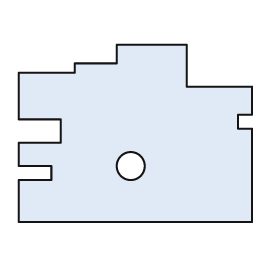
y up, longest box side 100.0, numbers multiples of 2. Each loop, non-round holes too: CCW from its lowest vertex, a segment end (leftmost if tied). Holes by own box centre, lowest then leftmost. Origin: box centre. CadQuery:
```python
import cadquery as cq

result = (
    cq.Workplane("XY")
    .moveTo(-50.0, -38.0)
    .lineTo(50.0, -38.0)
    .lineTo(50.0, 2.0)
    .lineTo(44.0, 2.0)
    .lineTo(44.0, 8.0)
    .lineTo(50.0, 8.0)
    .lineTo(50.0, 20.0)
    .lineTo(22.0, 20.0)
    .lineTo(22.0, 38.0)
    .lineTo(-8.0, 38.0)
    .lineTo(-8.0, 30.0)
    .lineTo(-26.0, 30.0)
    .lineTo(-26.0, 26.0)
    .lineTo(-50.0, 26.0)
    .lineTo(-50.0, 6.0)
    .lineTo(-32.0, 6.0)
    .lineTo(-32.0, -4.0)
    .lineTo(-50.0, -4.0)
    .lineTo(-50.0, -14.0)
    .lineTo(-36.0, -14.0)
    .lineTo(-36.0, -20.0)
    .lineTo(-50.0, -20.0)
    .close()
    .moveTo(-2.0, -14.0)
    .circle(6.0)
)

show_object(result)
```